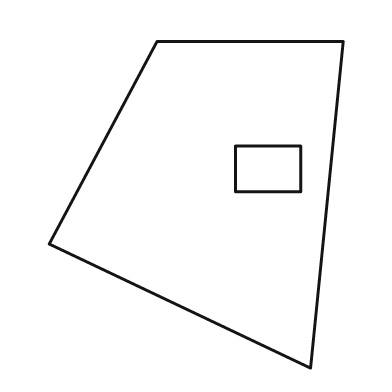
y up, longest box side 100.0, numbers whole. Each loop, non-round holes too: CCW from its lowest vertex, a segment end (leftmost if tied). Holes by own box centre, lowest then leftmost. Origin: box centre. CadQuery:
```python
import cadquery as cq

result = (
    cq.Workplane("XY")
    .moveTo(35.0, -50.0)
    .lineTo(45.0, 50.0)
    .lineTo(-12.0, 50.0)
    .lineTo(-45.0, -12.0)
    .close()
    .moveTo(12.0, 4.0)
    .lineTo(32.0, 4.0)
    .lineTo(32.0, 18.0)
    .lineTo(12.0, 18.0)
    .close()
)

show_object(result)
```